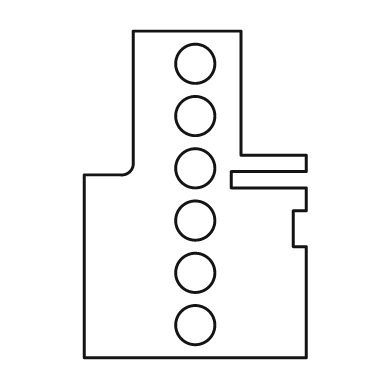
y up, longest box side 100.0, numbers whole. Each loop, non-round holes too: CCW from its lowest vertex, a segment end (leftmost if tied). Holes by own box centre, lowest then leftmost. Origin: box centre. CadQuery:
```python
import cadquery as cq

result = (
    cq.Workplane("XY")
    .moveTo(-34.0, -50.0)
    .lineTo(34.0, -50.0)
    .lineTo(34.0, -16.0)
    .lineTo(30.0, -16.0)
    .lineTo(30.0, -5.0)
    .lineTo(34.0, -5.0)
    .lineTo(34.0, 2.0)
    .lineTo(11.0, 2.0)
    .lineTo(11.0, 7.0)
    .lineTo(34.0, 7.0)
    .lineTo(34.0, 12.0)
    .lineTo(14.0, 12.0)
    .lineTo(14.0, 50.0)
    .lineTo(-19.0, 50.0)
    .lineTo(-19.0, 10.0)
    .threePointArc((-20.0, 7.0), (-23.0, 6.0))
    .lineTo(-34.0, 6.0)
    .close()
    .moveTo(0.0, -40.0)
    .circle(6.0)
    .moveTo(0.0, -24.0)
    .circle(6.0)
    .moveTo(0.0, -8.0)
    .circle(6.0)
    .moveTo(0.0, 8.0)
    .circle(6.0)
    .moveTo(0.0, 24.0)
    .circle(6.0)
    .moveTo(0.0, 40.0)
    .circle(6.0)
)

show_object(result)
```